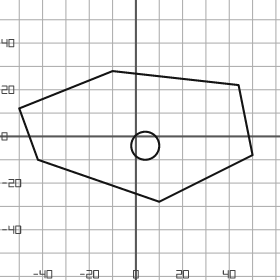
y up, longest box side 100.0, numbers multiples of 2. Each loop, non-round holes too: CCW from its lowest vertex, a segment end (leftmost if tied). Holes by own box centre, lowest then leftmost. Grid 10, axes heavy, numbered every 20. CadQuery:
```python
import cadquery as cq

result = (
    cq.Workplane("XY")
    .moveTo(10.0, -28.0)
    .lineTo(50.0, -8.0)
    .lineTo(44.0, 22.0)
    .lineTo(-10.0, 28.0)
    .lineTo(-50.0, 12.0)
    .lineTo(-42.0, -10.0)
    .close()
    .moveTo(4.0, -4.0)
    .circle(6.0)
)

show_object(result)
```